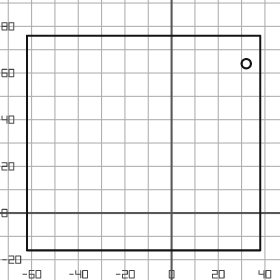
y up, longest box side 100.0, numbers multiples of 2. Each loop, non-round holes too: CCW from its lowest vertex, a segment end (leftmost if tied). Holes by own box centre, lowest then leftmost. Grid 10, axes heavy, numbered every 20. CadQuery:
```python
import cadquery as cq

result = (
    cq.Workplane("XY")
    .moveTo(-62.0, -16.0)
    .lineTo(38.0, -16.0)
    .lineTo(38.0, 76.0)
    .lineTo(-62.0, 76.0)
    .close()
    .moveTo(32.0, 64.0)
    .circle(2.0)
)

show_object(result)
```